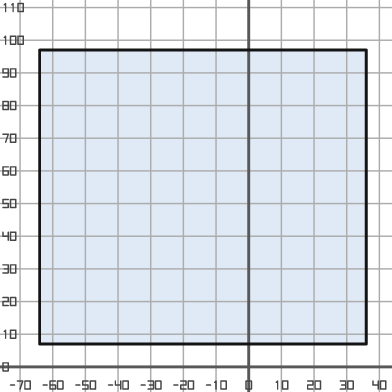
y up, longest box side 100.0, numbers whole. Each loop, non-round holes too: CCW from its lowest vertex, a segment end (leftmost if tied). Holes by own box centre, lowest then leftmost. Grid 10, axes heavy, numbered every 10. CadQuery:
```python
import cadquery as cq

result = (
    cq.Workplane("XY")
    .moveTo(-64.0, 7.0)
    .lineTo(36.0, 7.0)
    .lineTo(36.0, 97.0)
    .lineTo(-64.0, 97.0)
    .close()
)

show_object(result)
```